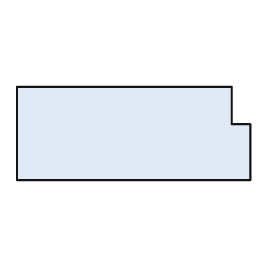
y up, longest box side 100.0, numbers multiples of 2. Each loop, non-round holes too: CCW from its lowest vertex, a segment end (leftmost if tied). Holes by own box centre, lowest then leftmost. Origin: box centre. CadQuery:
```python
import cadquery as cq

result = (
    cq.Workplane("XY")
    .moveTo(-50.0, -20.0)
    .lineTo(50.0, -20.0)
    .lineTo(50.0, 4.0)
    .lineTo(42.0, 4.0)
    .lineTo(42.0, 20.0)
    .lineTo(-50.0, 20.0)
    .close()
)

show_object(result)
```